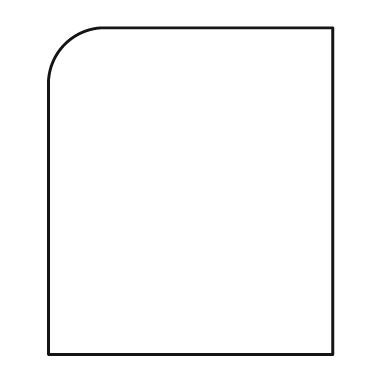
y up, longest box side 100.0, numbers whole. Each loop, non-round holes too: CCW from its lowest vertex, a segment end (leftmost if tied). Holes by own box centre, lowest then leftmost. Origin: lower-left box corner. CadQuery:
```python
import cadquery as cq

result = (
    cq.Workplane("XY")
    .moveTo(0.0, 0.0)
    .lineTo(87.0, 0.0)
    .lineTo(87.0, 100.0)
    .lineTo(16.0, 100.0)
    .threePointArc((5.0, 95.0), (0.0, 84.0))
    .close()
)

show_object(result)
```